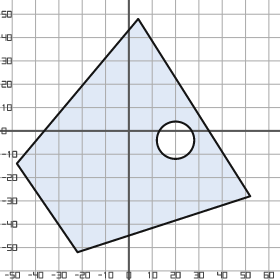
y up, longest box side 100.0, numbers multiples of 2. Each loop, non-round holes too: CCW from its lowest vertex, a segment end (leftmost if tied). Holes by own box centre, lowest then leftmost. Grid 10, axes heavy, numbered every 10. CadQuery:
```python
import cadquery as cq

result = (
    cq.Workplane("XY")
    .moveTo(-22.0, -52.0)
    .lineTo(52.0, -28.0)
    .lineTo(4.0, 48.0)
    .lineTo(-48.0, -14.0)
    .close()
    .moveTo(20.0, -4.0)
    .circle(8.0)
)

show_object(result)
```